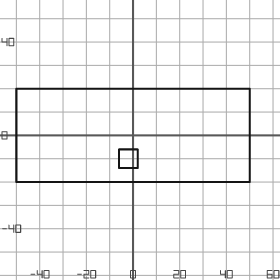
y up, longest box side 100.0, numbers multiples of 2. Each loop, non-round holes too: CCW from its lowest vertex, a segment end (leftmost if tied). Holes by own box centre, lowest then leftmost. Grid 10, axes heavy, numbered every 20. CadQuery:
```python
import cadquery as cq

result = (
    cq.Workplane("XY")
    .moveTo(-50.0, -20.0)
    .lineTo(50.0, -20.0)
    .lineTo(50.0, 20.0)
    .lineTo(-50.0, 20.0)
    .close()
    .moveTo(-6.0, -14.0)
    .lineTo(2.0, -14.0)
    .lineTo(2.0, -6.0)
    .lineTo(-6.0, -6.0)
    .close()
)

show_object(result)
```